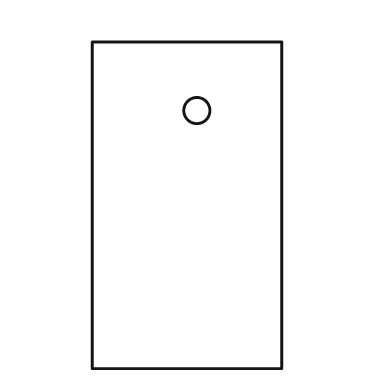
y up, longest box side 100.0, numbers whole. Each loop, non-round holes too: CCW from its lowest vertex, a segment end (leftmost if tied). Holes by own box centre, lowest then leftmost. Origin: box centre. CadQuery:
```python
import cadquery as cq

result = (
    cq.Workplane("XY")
    .moveTo(-29.0, -50.0)
    .lineTo(29.0, -50.0)
    .lineTo(29.0, 50.0)
    .lineTo(-29.0, 50.0)
    .close()
    .moveTo(3.0, 29.0)
    .circle(4.0)
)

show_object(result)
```